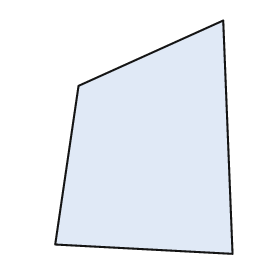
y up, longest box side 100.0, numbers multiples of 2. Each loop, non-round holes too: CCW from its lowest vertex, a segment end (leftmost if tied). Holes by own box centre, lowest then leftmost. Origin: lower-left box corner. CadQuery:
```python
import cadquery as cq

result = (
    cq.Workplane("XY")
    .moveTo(76.0, 0.0)
    .lineTo(72.0, 100.0)
    .lineTo(10.0, 72.0)
    .lineTo(0.0, 4.0)
    .close()
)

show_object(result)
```